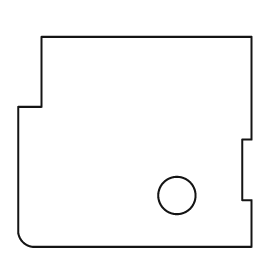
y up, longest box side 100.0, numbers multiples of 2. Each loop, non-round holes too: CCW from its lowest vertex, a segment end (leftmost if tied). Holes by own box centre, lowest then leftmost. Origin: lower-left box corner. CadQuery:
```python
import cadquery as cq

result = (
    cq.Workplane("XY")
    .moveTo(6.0, 0.0)
    .lineTo(100.0, 0.0)
    .lineTo(100.0, 20.0)
    .lineTo(96.0, 20.0)
    .lineTo(96.0, 46.0)
    .lineTo(100.0, 46.0)
    .lineTo(100.0, 90.0)
    .lineTo(10.0, 90.0)
    .lineTo(10.0, 60.0)
    .lineTo(0.0, 60.0)
    .lineTo(0.0, 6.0)
    .threePointArc((2.0, 2.0), (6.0, 0.0))
    .close()
    .moveTo(68.0, 22.0)
    .circle(8.0)
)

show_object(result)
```